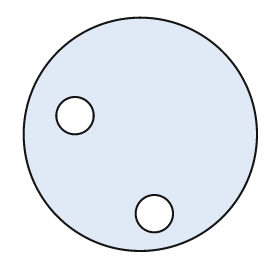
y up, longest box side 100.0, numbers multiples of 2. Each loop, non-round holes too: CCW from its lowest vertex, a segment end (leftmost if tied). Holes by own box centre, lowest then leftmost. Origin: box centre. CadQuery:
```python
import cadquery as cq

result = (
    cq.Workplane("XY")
    .moveTo(0.0, 0.0)
    .circle(50.0)
    .moveTo(6.0, -34.0)
    .circle(8.0)
    .moveTo(-28.0, 8.0)
    .circle(8.0)
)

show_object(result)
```